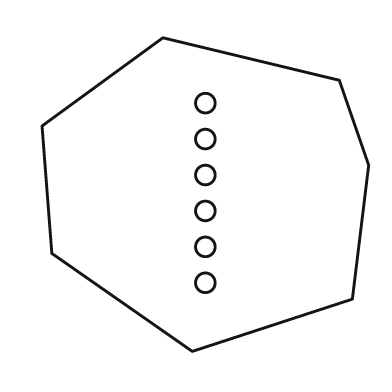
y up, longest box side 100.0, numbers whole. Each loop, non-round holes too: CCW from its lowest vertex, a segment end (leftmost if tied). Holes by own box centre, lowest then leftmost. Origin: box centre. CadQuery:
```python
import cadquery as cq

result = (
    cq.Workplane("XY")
    .moveTo(-4.0, -48.0)
    .lineTo(45.0, -32.0)
    .lineTo(50.0, 9.0)
    .lineTo(41.0, 35.0)
    .lineTo(-13.0, 48.0)
    .lineTo(-50.0, 21.0)
    .lineTo(-47.0, -18.0)
    .close()
    .moveTo(0.0, -27.0)
    .circle(3.0)
    .moveTo(0.0, -16.0)
    .circle(3.0)
    .moveTo(0.0, -5.0)
    .circle(3.0)
    .moveTo(0.0, 6.0)
    .circle(3.0)
    .moveTo(0.0, 17.0)
    .circle(3.0)
    .moveTo(0.0, 28.0)
    .circle(3.0)
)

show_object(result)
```